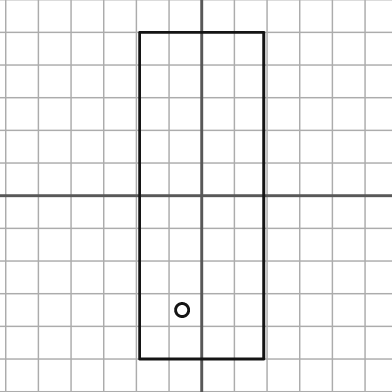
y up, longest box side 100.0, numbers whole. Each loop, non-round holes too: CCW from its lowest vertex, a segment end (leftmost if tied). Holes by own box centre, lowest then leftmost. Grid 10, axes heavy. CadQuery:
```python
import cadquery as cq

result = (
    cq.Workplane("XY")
    .moveTo(-19.0, -50.0)
    .lineTo(19.0, -50.0)
    .lineTo(19.0, 50.0)
    .lineTo(-19.0, 50.0)
    .close()
    .moveTo(-6.0, -35.0)
    .circle(2.0)
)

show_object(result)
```